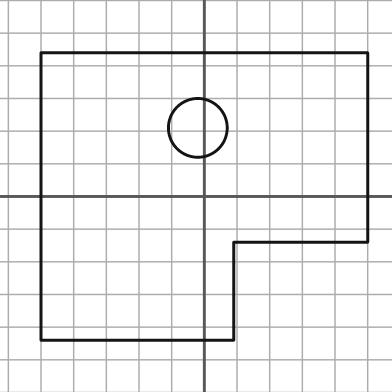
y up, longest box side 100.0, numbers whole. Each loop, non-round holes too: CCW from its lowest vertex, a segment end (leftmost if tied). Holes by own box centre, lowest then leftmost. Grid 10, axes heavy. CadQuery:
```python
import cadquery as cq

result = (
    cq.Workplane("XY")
    .moveTo(-50.0, -44.0)
    .lineTo(9.0, -44.0)
    .lineTo(9.0, -14.0)
    .lineTo(50.0, -14.0)
    .lineTo(50.0, 44.0)
    .lineTo(-50.0, 44.0)
    .close()
    .moveTo(-2.0, 21.0)
    .circle(9.0)
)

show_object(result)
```